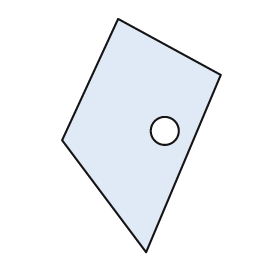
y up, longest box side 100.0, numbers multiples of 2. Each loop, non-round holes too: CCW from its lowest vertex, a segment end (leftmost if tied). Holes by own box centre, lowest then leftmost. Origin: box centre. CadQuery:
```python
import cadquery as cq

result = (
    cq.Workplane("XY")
    .moveTo(2.0, -50.0)
    .lineTo(34.0, 26.0)
    .lineTo(-10.0, 50.0)
    .lineTo(-34.0, -2.0)
    .close()
    .moveTo(10.0, 2.0)
    .circle(6.0)
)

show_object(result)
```